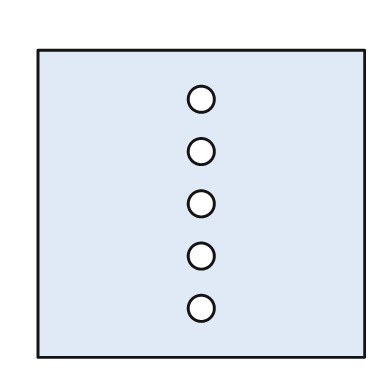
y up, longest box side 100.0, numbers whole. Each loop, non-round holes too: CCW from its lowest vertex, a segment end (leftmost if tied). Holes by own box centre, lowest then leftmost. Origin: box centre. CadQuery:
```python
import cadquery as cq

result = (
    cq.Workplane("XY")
    .moveTo(-50.0, -47.0)
    .lineTo(50.0, -47.0)
    .lineTo(50.0, 47.0)
    .lineTo(-50.0, 47.0)
    .close()
    .moveTo(0.0, -32.0)
    .circle(4.0)
    .moveTo(0.0, -16.0)
    .circle(4.0)
    .moveTo(0.0, 0.0)
    .circle(4.0)
    .moveTo(0.0, 16.0)
    .circle(4.0)
    .moveTo(0.0, 32.0)
    .circle(4.0)
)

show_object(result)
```